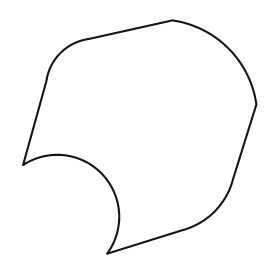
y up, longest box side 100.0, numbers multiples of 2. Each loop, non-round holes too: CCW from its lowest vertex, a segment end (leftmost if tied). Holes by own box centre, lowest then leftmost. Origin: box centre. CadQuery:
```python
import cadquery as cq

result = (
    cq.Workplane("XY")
    .moveTo(-14.0, -50.0)
    .lineTo(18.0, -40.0)
    .threePointArc((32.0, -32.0), (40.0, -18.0))
    .lineTo(50.0, 14.0)
    .threePointArc((38.0, 38.0), (14.0, 50.0))
    .lineTo(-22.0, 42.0)
    .threePointArc((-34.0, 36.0), (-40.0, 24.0))
    .lineTo(-50.0, -12.0)
    .threePointArc((-16.0, -16.0), (-14.0, -50.0))
    .close()
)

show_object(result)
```